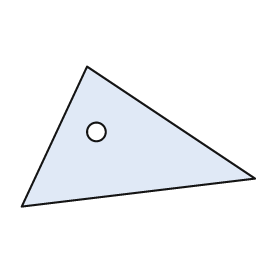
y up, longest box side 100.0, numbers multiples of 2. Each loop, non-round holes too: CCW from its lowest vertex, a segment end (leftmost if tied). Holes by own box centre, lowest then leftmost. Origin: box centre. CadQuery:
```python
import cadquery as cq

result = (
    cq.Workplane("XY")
    .moveTo(-50.0, -30.0)
    .lineTo(50.0, -18.0)
    .lineTo(-22.0, 30.0)
    .close()
    .moveTo(-18.0, 2.0)
    .circle(4.0)
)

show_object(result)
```